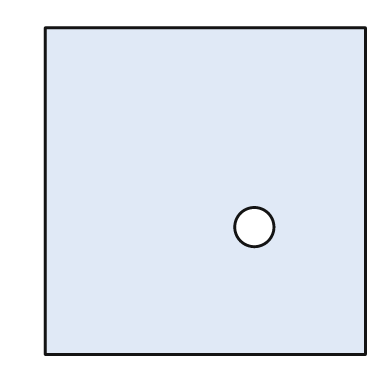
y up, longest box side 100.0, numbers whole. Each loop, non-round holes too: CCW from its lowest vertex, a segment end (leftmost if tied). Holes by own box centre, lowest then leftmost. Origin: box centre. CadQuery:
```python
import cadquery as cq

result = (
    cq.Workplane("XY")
    .moveTo(-49.0, -50.0)
    .lineTo(49.0, -50.0)
    .lineTo(49.0, 50.0)
    .lineTo(-49.0, 50.0)
    .close()
    .moveTo(15.0, -11.0)
    .circle(6.0)
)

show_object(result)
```